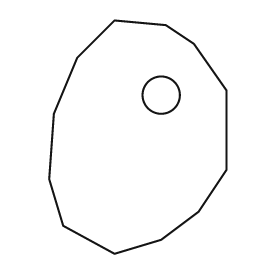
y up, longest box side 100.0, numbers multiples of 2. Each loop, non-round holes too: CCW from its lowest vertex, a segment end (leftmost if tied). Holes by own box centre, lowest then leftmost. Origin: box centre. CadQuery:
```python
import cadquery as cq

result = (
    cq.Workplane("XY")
    .moveTo(-10.0, -50.0)
    .lineTo(10.0, -44.0)
    .lineTo(26.0, -32.0)
    .lineTo(38.0, -14.0)
    .lineTo(38.0, 20.0)
    .lineTo(24.0, 40.0)
    .lineTo(12.0, 48.0)
    .lineTo(-10.0, 50.0)
    .lineTo(-26.0, 34.0)
    .lineTo(-36.0, 10.0)
    .lineTo(-38.0, -18.0)
    .lineTo(-32.0, -38.0)
    .close()
    .moveTo(10.0, 18.0)
    .circle(8.0)
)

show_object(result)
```